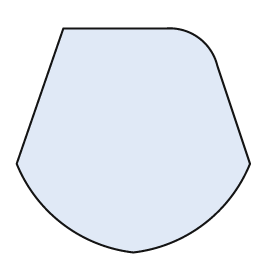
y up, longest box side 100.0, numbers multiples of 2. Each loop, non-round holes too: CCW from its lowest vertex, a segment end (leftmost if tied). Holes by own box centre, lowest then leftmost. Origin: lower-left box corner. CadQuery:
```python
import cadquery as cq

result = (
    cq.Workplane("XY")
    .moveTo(50.0, 0.0)
    .threePointArc((80.0, 12.0), (100.0, 38.0))
    .lineTo(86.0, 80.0)
    .threePointArc((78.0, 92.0), (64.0, 96.0))
    .lineTo(20.0, 96.0)
    .lineTo(0.0, 38.0)
    .threePointArc((20.0, 12.0), (50.0, 0.0))
    .close()
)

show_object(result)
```